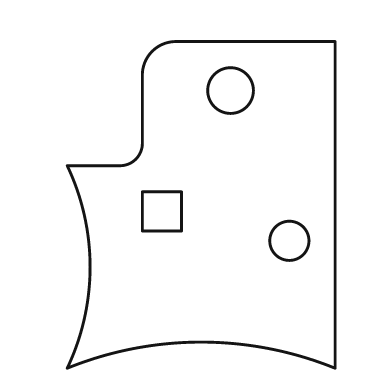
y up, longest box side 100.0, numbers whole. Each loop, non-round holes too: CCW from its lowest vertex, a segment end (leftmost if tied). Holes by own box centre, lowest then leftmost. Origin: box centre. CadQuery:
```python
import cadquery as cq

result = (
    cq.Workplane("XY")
    .moveTo(-41.0, -50.0)
    .threePointArc((0.0, -42.0), (41.0, -50.0))
    .lineTo(41.0, 50.0)
    .lineTo(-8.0, 50.0)
    .threePointArc((-15.0, 47.0), (-18.0, 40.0))
    .lineTo(-18.0, 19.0)
    .threePointArc((-20.0, 14.0), (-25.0, 12.0))
    .lineTo(-41.0, 12.0)
    .threePointArc((-34.0, -19.0), (-41.0, -50.0))
    .close()
    .moveTo(27.0, -11.0)
    .circle(6.0)
    .moveTo(-18.0, -8.0)
    .lineTo(-6.0, -8.0)
    .lineTo(-6.0, 4.0)
    .lineTo(-18.0, 4.0)
    .close()
    .moveTo(9.0, 35.0)
    .circle(7.0)
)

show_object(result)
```